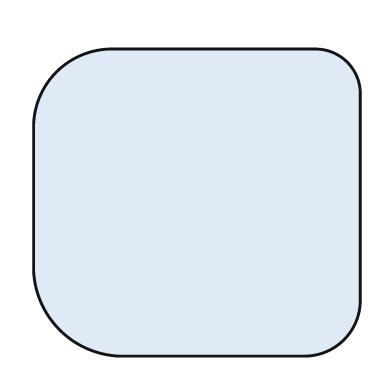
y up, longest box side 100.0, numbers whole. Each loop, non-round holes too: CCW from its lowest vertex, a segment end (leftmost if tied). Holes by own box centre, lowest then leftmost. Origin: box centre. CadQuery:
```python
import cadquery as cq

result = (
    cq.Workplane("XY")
    .moveTo(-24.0, -47.0)
    .lineTo(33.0, -47.0)
    .threePointArc((45.0, -42.0), (50.0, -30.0))
    .lineTo(50.0, 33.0)
    .threePointArc((46.0, 43.0), (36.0, 47.0))
    .lineTo(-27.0, 47.0)
    .threePointArc((-43.0, 40.0), (-50.0, 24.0))
    .lineTo(-50.0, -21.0)
    .threePointArc((-42.0, -39.0), (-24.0, -47.0))
    .close()
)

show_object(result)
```